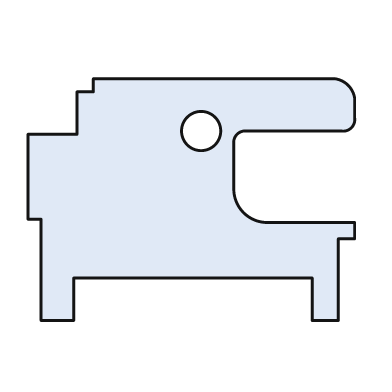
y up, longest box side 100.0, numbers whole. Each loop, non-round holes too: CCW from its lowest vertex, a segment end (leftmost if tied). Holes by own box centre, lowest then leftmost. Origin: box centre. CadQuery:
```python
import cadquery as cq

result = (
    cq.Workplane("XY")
    .moveTo(-46.0, -37.0)
    .lineTo(-36.0, -37.0)
    .lineTo(-36.0, -24.0)
    .lineTo(37.0, -24.0)
    .lineTo(37.0, -37.0)
    .lineTo(45.0, -37.0)
    .lineTo(45.0, -12.0)
    .lineTo(50.0, -12.0)
    .lineTo(50.0, -7.0)
    .lineTo(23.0, -7.0)
    .threePointArc((16.0, -4.0), (13.0, 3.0))
    .lineTo(13.0, 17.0)
    .threePointArc((14.0, 20.0), (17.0, 21.0))
    .lineTo(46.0, 21.0)
    .threePointArc((49.0, 22.0), (50.0, 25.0))
    .lineTo(50.0, 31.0)
    .threePointArc((48.0, 35.0), (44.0, 37.0))
    .lineTo(-30.0, 37.0)
    .lineTo(-30.0, 33.0)
    .lineTo(-35.0, 33.0)
    .lineTo(-35.0, 20.0)
    .lineTo(-50.0, 20.0)
    .lineTo(-50.0, -6.0)
    .lineTo(-46.0, -6.0)
    .close()
    .moveTo(3.0, 21.0)
    .circle(6.0)
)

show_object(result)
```